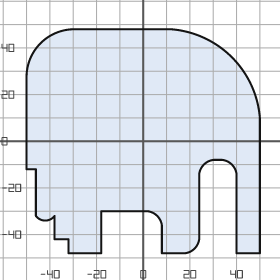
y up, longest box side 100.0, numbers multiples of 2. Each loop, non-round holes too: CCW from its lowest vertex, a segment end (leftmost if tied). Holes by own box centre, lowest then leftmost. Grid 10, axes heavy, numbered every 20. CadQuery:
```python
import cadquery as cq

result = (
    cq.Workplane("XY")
    .moveTo(-32.0, -48.0)
    .lineTo(-18.0, -48.0)
    .lineTo(-18.0, -30.0)
    .lineTo(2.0, -30.0)
    .threePointArc((6.0, -32.0), (8.0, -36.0))
    .lineTo(8.0, -48.0)
    .lineTo(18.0, -48.0)
    .threePointArc((22.0, -46.0), (24.0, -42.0))
    .lineTo(24.0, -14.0)
    .threePointArc((26.0, -10.0), (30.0, -8.0))
    .lineTo(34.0, -8.0)
    .threePointArc((38.0, -10.0), (40.0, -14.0))
    .lineTo(40.0, -48.0)
    .lineTo(50.0, -48.0)
    .lineTo(50.0, 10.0)
    .threePointArc((38.0, 36.0), (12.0, 48.0))
    .lineTo(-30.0, 48.0)
    .threePointArc((-44.0, 42.0), (-50.0, 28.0))
    .lineTo(-50.0, -12.0)
    .lineTo(-46.0, -12.0)
    .lineTo(-46.0, -32.0)
    .threePointArc((-42.0, -34.0), (-38.0, -32.0))
    .lineTo(-38.0, -42.0)
    .lineTo(-32.0, -42.0)
    .close()
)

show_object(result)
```